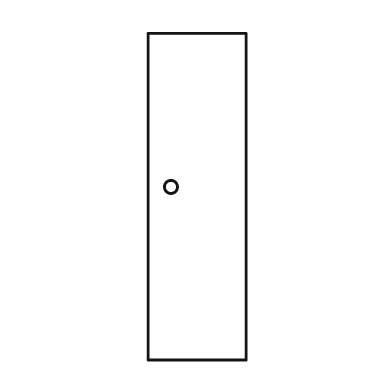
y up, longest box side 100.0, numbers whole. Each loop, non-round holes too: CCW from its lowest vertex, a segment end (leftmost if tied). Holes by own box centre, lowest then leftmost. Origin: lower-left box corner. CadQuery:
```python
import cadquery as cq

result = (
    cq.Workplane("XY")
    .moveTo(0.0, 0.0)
    .lineTo(30.0, 0.0)
    .lineTo(30.0, 100.0)
    .lineTo(0.0, 100.0)
    .close()
    .moveTo(7.0, 53.0)
    .circle(2.0)
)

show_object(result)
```